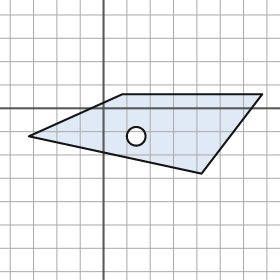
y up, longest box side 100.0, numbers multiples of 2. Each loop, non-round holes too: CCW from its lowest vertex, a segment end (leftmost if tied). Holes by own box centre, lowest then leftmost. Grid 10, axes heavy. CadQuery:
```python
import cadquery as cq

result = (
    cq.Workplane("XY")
    .moveTo(42.0, -28.0)
    .lineTo(68.0, 6.0)
    .lineTo(8.0, 6.0)
    .lineTo(-32.0, -12.0)
    .close()
    .moveTo(14.0, -12.0)
    .circle(4.0)
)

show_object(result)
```